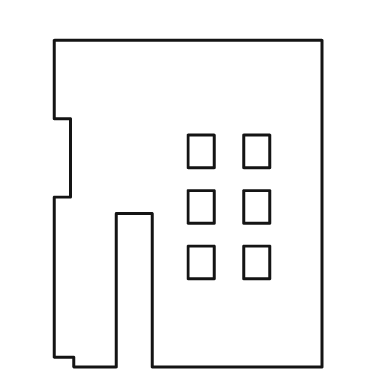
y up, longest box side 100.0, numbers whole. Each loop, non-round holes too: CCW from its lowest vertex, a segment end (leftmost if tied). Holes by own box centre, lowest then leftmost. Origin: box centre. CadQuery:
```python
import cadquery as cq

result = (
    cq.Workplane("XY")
    .moveTo(-35.0, -50.0)
    .lineTo(-22.0, -50.0)
    .lineTo(-22.0, -3.0)
    .lineTo(-11.0, -3.0)
    .lineTo(-11.0, -50.0)
    .lineTo(41.0, -50.0)
    .lineTo(41.0, 50.0)
    .lineTo(-41.0, 50.0)
    .lineTo(-41.0, 26.0)
    .lineTo(-36.0, 26.0)
    .lineTo(-36.0, 2.0)
    .lineTo(-41.0, 2.0)
    .lineTo(-41.0, -47.0)
    .lineTo(-35.0, -47.0)
    .close()
    .moveTo(0.0, -23.0)
    .lineTo(8.0, -23.0)
    .lineTo(8.0, -13.0)
    .lineTo(0.0, -13.0)
    .close()
    .moveTo(17.0, -23.0)
    .lineTo(25.0, -23.0)
    .lineTo(25.0, -13.0)
    .lineTo(17.0, -13.0)
    .close()
    .moveTo(0.0, -6.0)
    .lineTo(8.0, -6.0)
    .lineTo(8.0, 4.0)
    .lineTo(0.0, 4.0)
    .close()
    .moveTo(17.0, -6.0)
    .lineTo(25.0, -6.0)
    .lineTo(25.0, 4.0)
    .lineTo(17.0, 4.0)
    .close()
    .moveTo(0.0, 11.0)
    .lineTo(8.0, 11.0)
    .lineTo(8.0, 21.0)
    .lineTo(0.0, 21.0)
    .close()
    .moveTo(17.0, 11.0)
    .lineTo(25.0, 11.0)
    .lineTo(25.0, 21.0)
    .lineTo(17.0, 21.0)
    .close()
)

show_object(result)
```